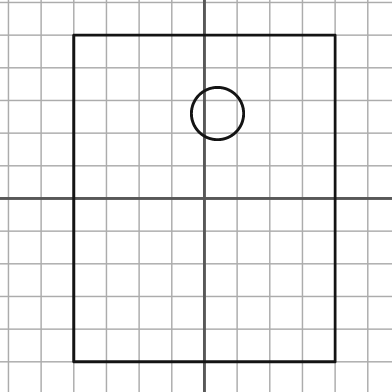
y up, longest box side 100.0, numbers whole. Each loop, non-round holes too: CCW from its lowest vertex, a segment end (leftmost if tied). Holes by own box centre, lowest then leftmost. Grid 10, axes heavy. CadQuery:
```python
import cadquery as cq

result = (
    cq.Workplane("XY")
    .moveTo(-40.0, -50.0)
    .lineTo(40.0, -50.0)
    .lineTo(40.0, 50.0)
    .lineTo(-40.0, 50.0)
    .close()
    .moveTo(4.0, 26.0)
    .circle(8.0)
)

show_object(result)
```